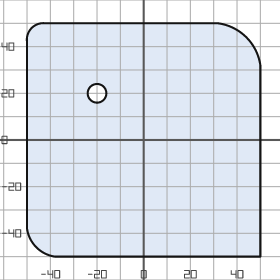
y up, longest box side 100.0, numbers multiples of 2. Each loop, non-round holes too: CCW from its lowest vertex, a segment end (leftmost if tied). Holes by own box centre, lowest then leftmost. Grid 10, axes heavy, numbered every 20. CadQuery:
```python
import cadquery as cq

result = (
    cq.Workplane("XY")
    .moveTo(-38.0, -50.0)
    .lineTo(50.0, -50.0)
    .lineTo(50.0, 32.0)
    .threePointArc((44.0, 44.0), (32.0, 50.0))
    .lineTo(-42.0, 50.0)
    .threePointArc((-48.0, 48.0), (-50.0, 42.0))
    .lineTo(-50.0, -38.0)
    .threePointArc((-46.0, -46.0), (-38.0, -50.0))
    .close()
    .moveTo(-20.0, 20.0)
    .circle(4.0)
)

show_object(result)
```